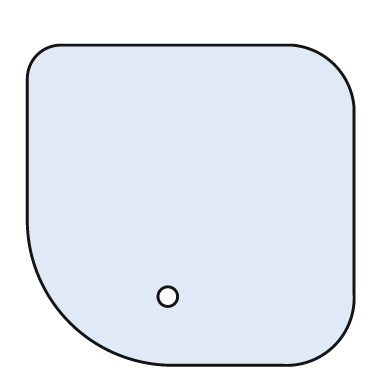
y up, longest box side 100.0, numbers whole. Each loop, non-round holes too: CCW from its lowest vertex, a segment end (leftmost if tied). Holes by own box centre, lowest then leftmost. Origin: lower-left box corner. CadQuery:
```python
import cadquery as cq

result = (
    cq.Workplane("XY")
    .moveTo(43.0, 0.0)
    .lineTo(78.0, 0.0)
    .threePointArc((94.0, 6.0), (100.0, 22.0))
    .lineTo(100.0, 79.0)
    .threePointArc((94.0, 92.0), (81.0, 98.0))
    .lineTo(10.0, 98.0)
    .threePointArc((3.0, 95.0), (0.0, 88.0))
    .lineTo(0.0, 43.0)
    .threePointArc((13.0, 13.0), (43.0, 0.0))
    .close()
    .moveTo(43.0, 21.0)
    .circle(3.0)
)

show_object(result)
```